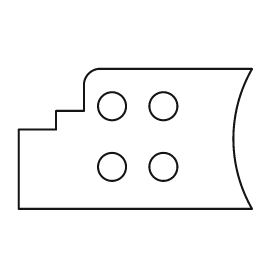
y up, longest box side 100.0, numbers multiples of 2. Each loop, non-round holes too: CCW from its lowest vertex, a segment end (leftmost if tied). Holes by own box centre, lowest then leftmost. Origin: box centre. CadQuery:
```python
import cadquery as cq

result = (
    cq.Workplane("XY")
    .moveTo(-50.0, -30.0)
    .lineTo(50.0, -30.0)
    .threePointArc((42.0, 0.0), (50.0, 30.0))
    .lineTo(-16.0, 30.0)
    .threePointArc((-20.0, 28.0), (-22.0, 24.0))
    .lineTo(-22.0, 12.0)
    .lineTo(-34.0, 12.0)
    .lineTo(-34.0, 4.0)
    .lineTo(-50.0, 4.0)
    .close()
    .moveTo(-10.0, -12.0)
    .circle(6.0)
    .moveTo(12.0, -12.0)
    .circle(6.0)
    .moveTo(-10.0, 14.0)
    .circle(6.0)
    .moveTo(12.0, 14.0)
    .circle(6.0)
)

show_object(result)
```